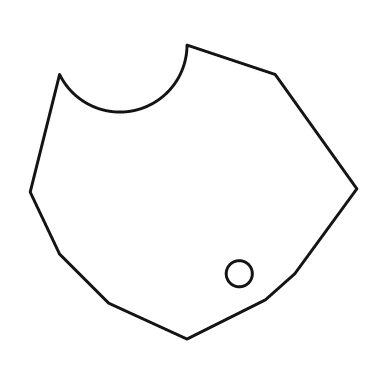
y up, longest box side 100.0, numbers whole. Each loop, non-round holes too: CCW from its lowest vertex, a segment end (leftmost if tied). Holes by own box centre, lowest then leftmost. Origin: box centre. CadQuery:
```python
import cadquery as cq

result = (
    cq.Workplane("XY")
    .moveTo(-2.0, -45.0)
    .lineTo(22.0, -33.0)
    .lineTo(31.0, -25.0)
    .lineTo(50.0, 1.0)
    .lineTo(25.0, 36.0)
    .lineTo(-2.0, 45.0)
    .threePointArc((-18.0, 25.0), (-41.0, 36.0))
    .lineTo(-50.0, 0.0)
    .lineTo(-41.0, -19.0)
    .lineTo(-26.0, -34.0)
    .close()
    .moveTo(14.0, -25.0)
    .circle(4.0)
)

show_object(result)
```